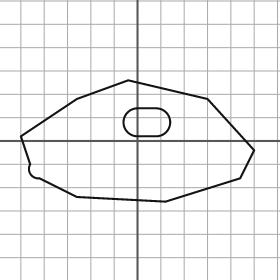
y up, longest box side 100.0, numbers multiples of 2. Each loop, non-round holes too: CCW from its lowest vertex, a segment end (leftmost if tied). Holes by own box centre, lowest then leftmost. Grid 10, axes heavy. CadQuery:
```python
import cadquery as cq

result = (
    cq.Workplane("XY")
    .moveTo(12.0, -26.0)
    .lineTo(44.0, -16.0)
    .lineTo(50.0, -4.0)
    .lineTo(30.0, 18.0)
    .lineTo(-4.0, 26.0)
    .lineTo(-26.0, 18.0)
    .lineTo(-50.0, 2.0)
    .lineTo(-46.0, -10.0)
    .threePointArc((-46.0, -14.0), (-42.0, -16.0))
    .lineTo(-26.0, -24.0)
    .close()
    .moveTo(0.0, 2.0)
    .lineTo(8.0, 2.0)
    .threePointArc((14.0, 8.0), (8.0, 14.0))
    .lineTo(0.0, 14.0)
    .threePointArc((-6.0, 8.0), (0.0, 2.0))
    .close()
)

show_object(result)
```